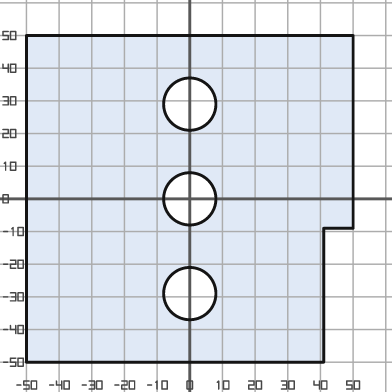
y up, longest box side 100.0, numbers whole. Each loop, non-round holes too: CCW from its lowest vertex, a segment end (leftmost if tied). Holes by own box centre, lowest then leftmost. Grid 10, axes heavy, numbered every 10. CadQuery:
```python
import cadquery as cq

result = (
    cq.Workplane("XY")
    .moveTo(-50.0, -50.0)
    .lineTo(41.0, -50.0)
    .lineTo(41.0, -9.0)
    .lineTo(50.0, -9.0)
    .lineTo(50.0, 50.0)
    .lineTo(-50.0, 50.0)
    .close()
    .moveTo(0.0, -29.0)
    .circle(8.0)
    .moveTo(0.0, 0.0)
    .circle(8.0)
    .moveTo(0.0, 29.0)
    .circle(8.0)
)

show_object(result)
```